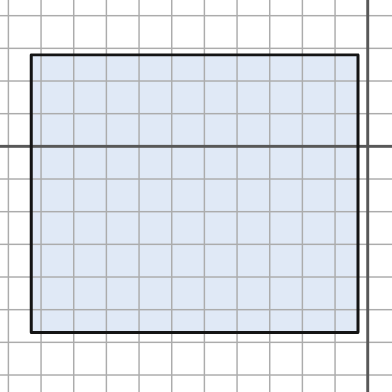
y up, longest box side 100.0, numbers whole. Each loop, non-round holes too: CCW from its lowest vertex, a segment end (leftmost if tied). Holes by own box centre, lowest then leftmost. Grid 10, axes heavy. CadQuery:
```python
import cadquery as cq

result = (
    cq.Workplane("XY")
    .moveTo(-103.0, -57.0)
    .lineTo(-3.0, -57.0)
    .lineTo(-3.0, 28.0)
    .lineTo(-103.0, 28.0)
    .close()
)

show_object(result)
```